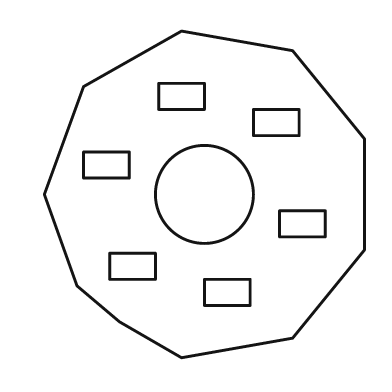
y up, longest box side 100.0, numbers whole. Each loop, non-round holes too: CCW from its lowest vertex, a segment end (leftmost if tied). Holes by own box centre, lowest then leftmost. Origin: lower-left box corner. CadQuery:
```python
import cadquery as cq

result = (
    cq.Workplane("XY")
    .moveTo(42.0, 0.0)
    .lineTo(76.0, 6.0)
    .lineTo(98.0, 33.0)
    .lineTo(98.0, 67.0)
    .lineTo(76.0, 94.0)
    .lineTo(42.0, 100.0)
    .lineTo(12.0, 83.0)
    .lineTo(0.0, 50.0)
    .lineTo(10.0, 22.0)
    .lineTo(23.0, 11.0)
    .close()
    .moveTo(49.0, 16.0)
    .lineTo(63.0, 16.0)
    .lineTo(63.0, 24.0)
    .lineTo(49.0, 24.0)
    .close()
    .moveTo(20.0, 24.0)
    .lineTo(34.0, 24.0)
    .lineTo(34.0, 32.0)
    .lineTo(20.0, 32.0)
    .close()
    .moveTo(72.0, 37.0)
    .lineTo(86.0, 37.0)
    .lineTo(86.0, 45.0)
    .lineTo(72.0, 45.0)
    .close()
    .moveTo(49.0, 50.0)
    .circle(15.0)
    .moveTo(12.0, 55.0)
    .lineTo(26.0, 55.0)
    .lineTo(26.0, 63.0)
    .lineTo(12.0, 63.0)
    .close()
    .moveTo(64.0, 68.0)
    .lineTo(78.0, 68.0)
    .lineTo(78.0, 76.0)
    .lineTo(64.0, 76.0)
    .close()
    .moveTo(35.0, 76.0)
    .lineTo(49.0, 76.0)
    .lineTo(49.0, 84.0)
    .lineTo(35.0, 84.0)
    .close()
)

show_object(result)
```